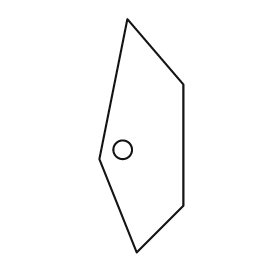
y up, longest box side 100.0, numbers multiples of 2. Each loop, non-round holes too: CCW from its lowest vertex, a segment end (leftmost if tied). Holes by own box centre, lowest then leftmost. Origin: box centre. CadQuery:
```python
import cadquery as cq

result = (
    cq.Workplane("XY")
    .moveTo(-2.0, -50.0)
    .lineTo(18.0, -30.0)
    .lineTo(18.0, 22.0)
    .lineTo(-6.0, 50.0)
    .lineTo(-18.0, -10.0)
    .close()
    .moveTo(-8.0, -6.0)
    .circle(4.0)
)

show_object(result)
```